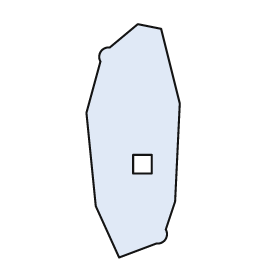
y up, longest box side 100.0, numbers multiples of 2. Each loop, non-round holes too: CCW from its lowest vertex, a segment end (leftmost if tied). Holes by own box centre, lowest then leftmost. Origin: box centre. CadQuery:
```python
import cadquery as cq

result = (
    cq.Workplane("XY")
    .moveTo(-6.0, -50.0)
    .lineTo(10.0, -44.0)
    .threePointArc((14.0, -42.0), (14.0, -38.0))
    .lineTo(18.0, -26.0)
    .lineTo(20.0, 16.0)
    .lineTo(12.0, 48.0)
    .lineTo(2.0, 50.0)
    .lineTo(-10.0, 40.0)
    .threePointArc((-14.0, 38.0), (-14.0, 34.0))
    .lineTo(-20.0, 12.0)
    .lineTo(-16.0, -28.0)
    .close()
    .moveTo(0.0, -14.0)
    .lineTo(8.0, -14.0)
    .lineTo(8.0, -6.0)
    .lineTo(0.0, -6.0)
    .close()
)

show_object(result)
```